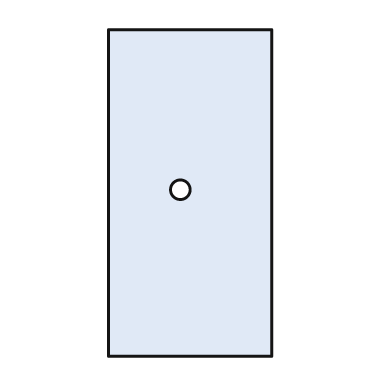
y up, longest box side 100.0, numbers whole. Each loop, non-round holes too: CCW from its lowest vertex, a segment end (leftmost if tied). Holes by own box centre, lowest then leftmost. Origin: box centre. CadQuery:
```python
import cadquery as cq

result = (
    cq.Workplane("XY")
    .moveTo(-25.0, -50.0)
    .lineTo(25.0, -50.0)
    .lineTo(25.0, 50.0)
    .lineTo(-25.0, 50.0)
    .close()
    .moveTo(-3.0, 1.0)
    .circle(3.0)
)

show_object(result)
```